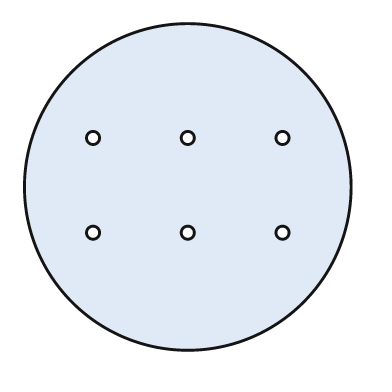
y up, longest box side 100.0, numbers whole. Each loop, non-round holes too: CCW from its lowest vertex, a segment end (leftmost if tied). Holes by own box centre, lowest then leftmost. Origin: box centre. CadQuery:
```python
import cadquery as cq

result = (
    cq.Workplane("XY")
    .moveTo(0.0, 0.0)
    .circle(50.0)
    .moveTo(-29.0, -14.0)
    .circle(2.0)
    .moveTo(0.0, -14.0)
    .circle(2.0)
    .moveTo(29.0, -14.0)
    .circle(2.0)
    .moveTo(-29.0, 15.0)
    .circle(2.0)
    .moveTo(0.0, 15.0)
    .circle(2.0)
    .moveTo(29.0, 15.0)
    .circle(2.0)
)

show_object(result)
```